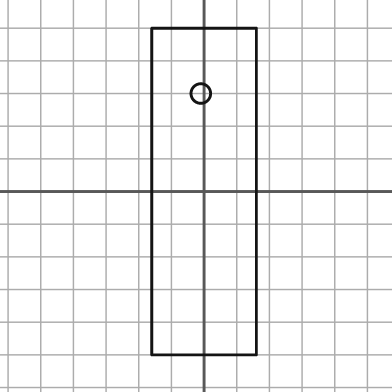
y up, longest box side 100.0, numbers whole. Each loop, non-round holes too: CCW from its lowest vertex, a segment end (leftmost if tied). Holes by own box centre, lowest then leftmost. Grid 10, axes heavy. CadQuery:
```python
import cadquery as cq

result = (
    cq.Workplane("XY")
    .moveTo(-16.0, -50.0)
    .lineTo(16.0, -50.0)
    .lineTo(16.0, 50.0)
    .lineTo(-16.0, 50.0)
    .close()
    .moveTo(-1.0, 30.0)
    .circle(3.0)
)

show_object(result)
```